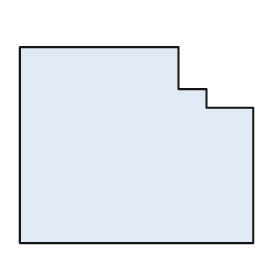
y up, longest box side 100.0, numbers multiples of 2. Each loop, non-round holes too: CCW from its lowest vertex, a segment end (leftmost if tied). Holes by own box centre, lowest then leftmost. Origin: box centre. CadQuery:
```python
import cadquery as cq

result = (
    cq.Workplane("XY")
    .moveTo(-50.0, -42.0)
    .lineTo(50.0, -42.0)
    .lineTo(50.0, 16.0)
    .lineTo(30.0, 16.0)
    .lineTo(30.0, 24.0)
    .lineTo(18.0, 24.0)
    .lineTo(18.0, 42.0)
    .lineTo(-50.0, 42.0)
    .close()
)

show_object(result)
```